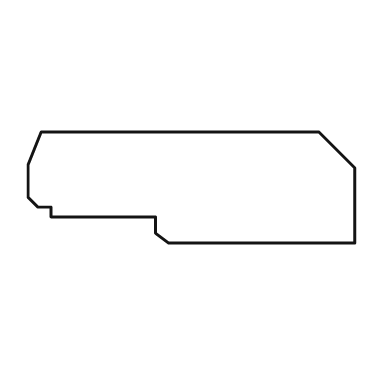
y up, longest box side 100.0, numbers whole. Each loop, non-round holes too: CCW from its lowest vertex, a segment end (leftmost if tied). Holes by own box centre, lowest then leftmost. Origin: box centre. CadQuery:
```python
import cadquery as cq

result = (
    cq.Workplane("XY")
    .moveTo(-7.0, -17.0)
    .lineTo(50.0, -17.0)
    .lineTo(50.0, 6.0)
    .lineTo(39.0, 17.0)
    .lineTo(-46.0, 17.0)
    .lineTo(-50.0, 7.0)
    .lineTo(-50.0, -3.0)
    .lineTo(-47.0, -6.0)
    .lineTo(-43.0, -6.0)
    .lineTo(-43.0, -9.0)
    .lineTo(-11.0, -9.0)
    .lineTo(-11.0, -14.0)
    .close()
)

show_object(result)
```